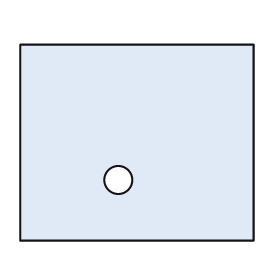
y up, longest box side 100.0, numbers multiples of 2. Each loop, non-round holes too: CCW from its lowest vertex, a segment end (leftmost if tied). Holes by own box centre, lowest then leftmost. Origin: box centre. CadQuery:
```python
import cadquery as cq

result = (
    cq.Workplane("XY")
    .moveTo(-50.0, -42.0)
    .lineTo(50.0, -42.0)
    .lineTo(50.0, 42.0)
    .lineTo(-50.0, 42.0)
    .close()
    .moveTo(-8.0, -16.0)
    .circle(6.0)
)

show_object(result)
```